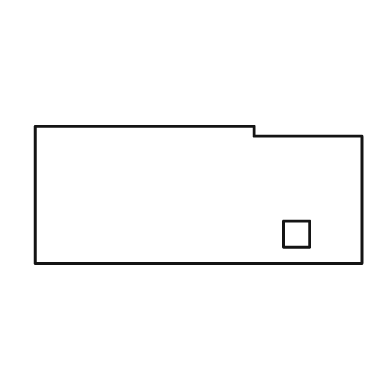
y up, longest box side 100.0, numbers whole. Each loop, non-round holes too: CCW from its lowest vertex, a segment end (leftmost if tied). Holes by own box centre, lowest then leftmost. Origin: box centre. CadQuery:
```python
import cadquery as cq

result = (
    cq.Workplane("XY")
    .moveTo(-50.0, -21.0)
    .lineTo(50.0, -21.0)
    .lineTo(50.0, 18.0)
    .lineTo(17.0, 18.0)
    .lineTo(17.0, 21.0)
    .lineTo(-50.0, 21.0)
    .close()
    .moveTo(26.0, -16.0)
    .lineTo(34.0, -16.0)
    .lineTo(34.0, -8.0)
    .lineTo(26.0, -8.0)
    .close()
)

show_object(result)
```